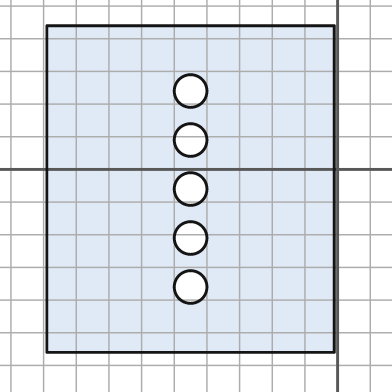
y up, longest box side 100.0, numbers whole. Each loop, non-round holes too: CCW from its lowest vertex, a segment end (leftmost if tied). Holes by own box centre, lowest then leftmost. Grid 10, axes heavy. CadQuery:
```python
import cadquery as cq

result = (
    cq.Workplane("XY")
    .moveTo(-89.0, -56.0)
    .lineTo(-1.0, -56.0)
    .lineTo(-1.0, 44.0)
    .lineTo(-89.0, 44.0)
    .close()
    .moveTo(-45.0, -36.0)
    .circle(5.0)
    .moveTo(-45.0, -21.0)
    .circle(5.0)
    .moveTo(-45.0, -6.0)
    .circle(5.0)
    .moveTo(-45.0, 9.0)
    .circle(5.0)
    .moveTo(-45.0, 24.0)
    .circle(5.0)
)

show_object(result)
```